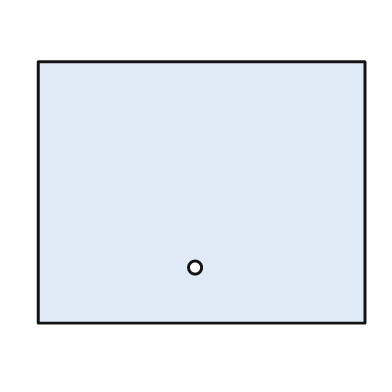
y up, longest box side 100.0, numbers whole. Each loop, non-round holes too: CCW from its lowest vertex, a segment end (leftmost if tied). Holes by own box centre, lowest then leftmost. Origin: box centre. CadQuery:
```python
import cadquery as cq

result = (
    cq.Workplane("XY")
    .moveTo(-50.0, -40.0)
    .lineTo(50.0, -40.0)
    .lineTo(50.0, 40.0)
    .lineTo(-50.0, 40.0)
    .close()
    .moveTo(-2.0, -23.0)
    .circle(2.0)
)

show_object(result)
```